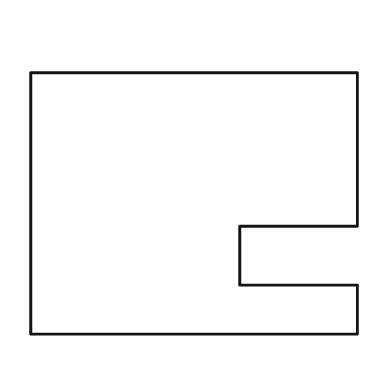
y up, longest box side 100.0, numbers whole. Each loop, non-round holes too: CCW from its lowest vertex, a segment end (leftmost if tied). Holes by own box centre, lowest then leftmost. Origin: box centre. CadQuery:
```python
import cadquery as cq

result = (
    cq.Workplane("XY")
    .moveTo(-50.0, -40.0)
    .lineTo(50.0, -40.0)
    .lineTo(50.0, -25.0)
    .lineTo(14.0, -25.0)
    .lineTo(14.0, -7.0)
    .lineTo(50.0, -7.0)
    .lineTo(50.0, 40.0)
    .lineTo(-50.0, 40.0)
    .close()
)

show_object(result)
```